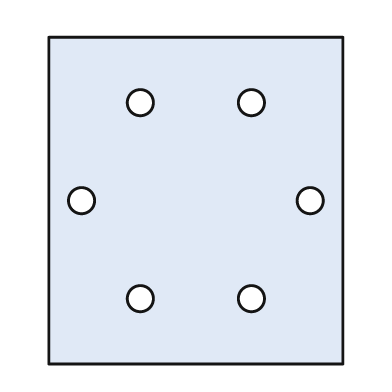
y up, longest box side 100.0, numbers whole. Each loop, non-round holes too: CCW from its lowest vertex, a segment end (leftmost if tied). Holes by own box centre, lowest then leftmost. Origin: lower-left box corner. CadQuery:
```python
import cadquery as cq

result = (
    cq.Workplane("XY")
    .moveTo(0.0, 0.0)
    .lineTo(90.0, 0.0)
    .lineTo(90.0, 100.0)
    .lineTo(0.0, 100.0)
    .close()
    .moveTo(28.0, 20.0)
    .circle(4.0)
    .moveTo(62.0, 20.0)
    .circle(4.0)
    .moveTo(10.0, 50.0)
    .circle(4.0)
    .moveTo(80.0, 50.0)
    .circle(4.0)
    .moveTo(28.0, 80.0)
    .circle(4.0)
    .moveTo(62.0, 80.0)
    .circle(4.0)
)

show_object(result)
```